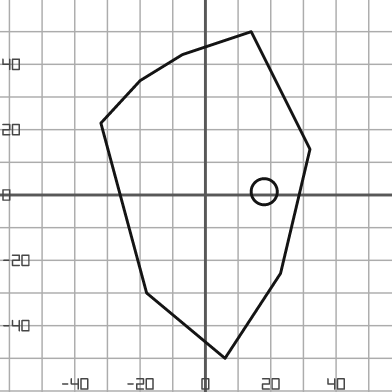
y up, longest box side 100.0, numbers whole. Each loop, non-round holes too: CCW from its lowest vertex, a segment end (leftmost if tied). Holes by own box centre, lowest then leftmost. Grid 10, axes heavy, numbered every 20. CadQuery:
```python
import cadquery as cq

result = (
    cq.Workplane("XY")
    .moveTo(6.0, -50.0)
    .lineTo(23.0, -24.0)
    .lineTo(32.0, 14.0)
    .lineTo(14.0, 50.0)
    .lineTo(-7.0, 43.0)
    .lineTo(-20.0, 35.0)
    .lineTo(-32.0, 22.0)
    .lineTo(-18.0, -30.0)
    .close()
    .moveTo(18.0, 1.0)
    .circle(4.0)
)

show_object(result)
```